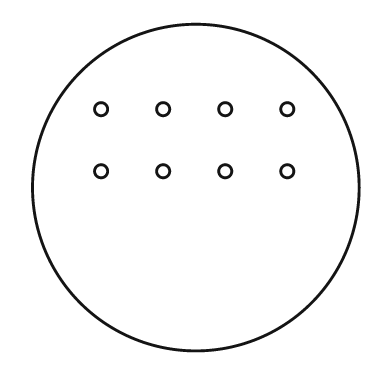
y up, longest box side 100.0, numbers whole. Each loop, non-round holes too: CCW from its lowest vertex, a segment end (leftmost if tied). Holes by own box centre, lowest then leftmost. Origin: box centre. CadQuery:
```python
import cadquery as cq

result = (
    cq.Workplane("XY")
    .moveTo(0.0, 0.0)
    .circle(50.0)
    .moveTo(-29.0, 5.0)
    .circle(2.0)
    .moveTo(-10.0, 5.0)
    .circle(2.0)
    .moveTo(9.0, 5.0)
    .circle(2.0)
    .moveTo(28.0, 5.0)
    .circle(2.0)
    .moveTo(-29.0, 24.0)
    .circle(2.0)
    .moveTo(-10.0, 24.0)
    .circle(2.0)
    .moveTo(9.0, 24.0)
    .circle(2.0)
    .moveTo(28.0, 24.0)
    .circle(2.0)
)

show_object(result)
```